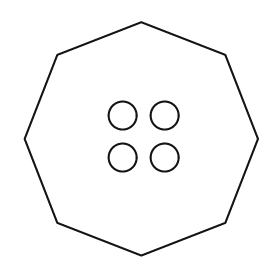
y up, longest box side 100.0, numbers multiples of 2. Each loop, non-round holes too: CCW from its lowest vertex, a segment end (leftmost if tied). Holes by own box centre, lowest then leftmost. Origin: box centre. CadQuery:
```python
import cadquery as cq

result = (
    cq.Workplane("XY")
    .moveTo(0.0, -50.0)
    .lineTo(36.0, -36.0)
    .lineTo(50.0, 0.0)
    .lineTo(36.0, 36.0)
    .lineTo(0.0, 50.0)
    .lineTo(-36.0, 36.0)
    .lineTo(-50.0, 0.0)
    .lineTo(-36.0, -36.0)
    .close()
    .moveTo(-8.0, -8.0)
    .circle(6.0)
    .moveTo(10.0, -8.0)
    .circle(6.0)
    .moveTo(-8.0, 10.0)
    .circle(6.0)
    .moveTo(10.0, 10.0)
    .circle(6.0)
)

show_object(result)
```